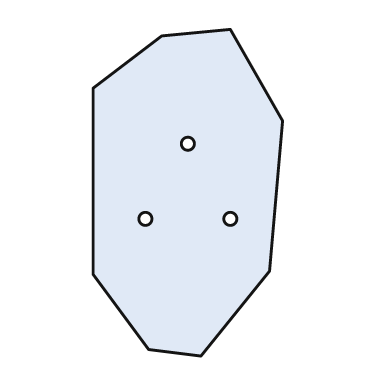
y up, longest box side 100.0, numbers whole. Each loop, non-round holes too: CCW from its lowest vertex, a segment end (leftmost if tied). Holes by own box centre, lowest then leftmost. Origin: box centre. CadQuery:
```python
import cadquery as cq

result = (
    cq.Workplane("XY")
    .moveTo(4.0, -50.0)
    .lineTo(25.0, -24.0)
    .lineTo(29.0, 22.0)
    .lineTo(13.0, 50.0)
    .lineTo(-8.0, 48.0)
    .lineTo(-29.0, 32.0)
    .lineTo(-29.0, -25.0)
    .lineTo(-12.0, -48.0)
    .close()
    .moveTo(-13.0, -8.0)
    .circle(2.0)
    .moveTo(13.0, -8.0)
    .circle(2.0)
    .moveTo(0.0, 15.0)
    .circle(2.0)
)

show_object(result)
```